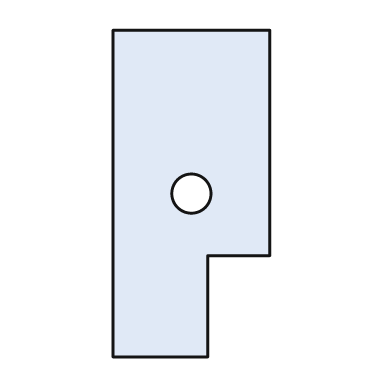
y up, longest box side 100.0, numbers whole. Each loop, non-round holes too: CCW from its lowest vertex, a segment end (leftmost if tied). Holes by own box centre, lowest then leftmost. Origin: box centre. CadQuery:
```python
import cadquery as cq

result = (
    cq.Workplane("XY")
    .moveTo(-24.0, -50.0)
    .lineTo(5.0, -50.0)
    .lineTo(5.0, -19.0)
    .lineTo(24.0, -19.0)
    .lineTo(24.0, 50.0)
    .lineTo(-24.0, 50.0)
    .close()
    .moveTo(0.0, 0.0)
    .circle(6.0)
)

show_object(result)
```